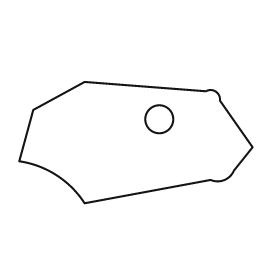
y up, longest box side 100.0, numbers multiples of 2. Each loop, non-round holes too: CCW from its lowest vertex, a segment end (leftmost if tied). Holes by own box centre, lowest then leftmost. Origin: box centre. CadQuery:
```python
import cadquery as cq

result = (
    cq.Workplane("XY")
    .moveTo(-22.0, -26.0)
    .lineTo(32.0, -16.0)
    .threePointArc((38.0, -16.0), (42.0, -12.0))
    .lineTo(50.0, -2.0)
    .lineTo(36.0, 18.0)
    .threePointArc((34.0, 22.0), (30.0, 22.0))
    .lineTo(-22.0, 26.0)
    .lineTo(-44.0, 14.0)
    .lineTo(-50.0, -8.0)
    .threePointArc((-34.0, -14.0), (-22.0, -26.0))
    .close()
    .moveTo(10.0, 10.0)
    .circle(6.0)
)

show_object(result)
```